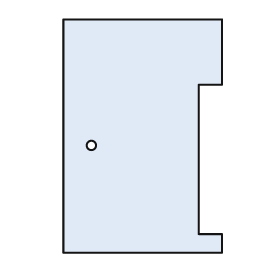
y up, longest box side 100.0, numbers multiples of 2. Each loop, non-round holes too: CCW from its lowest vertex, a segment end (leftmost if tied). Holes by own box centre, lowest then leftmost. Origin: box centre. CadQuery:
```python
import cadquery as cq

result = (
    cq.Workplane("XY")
    .moveTo(-34.0, -50.0)
    .lineTo(34.0, -50.0)
    .lineTo(34.0, -42.0)
    .lineTo(24.0, -42.0)
    .lineTo(24.0, 22.0)
    .lineTo(34.0, 22.0)
    .lineTo(34.0, 50.0)
    .lineTo(-34.0, 50.0)
    .close()
    .moveTo(-22.0, -4.0)
    .circle(2.0)
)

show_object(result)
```